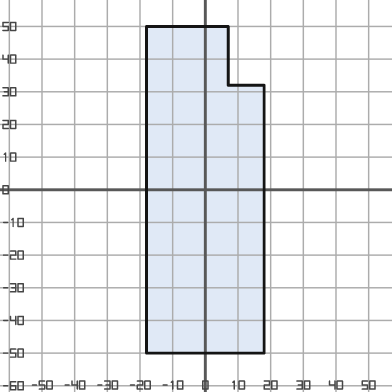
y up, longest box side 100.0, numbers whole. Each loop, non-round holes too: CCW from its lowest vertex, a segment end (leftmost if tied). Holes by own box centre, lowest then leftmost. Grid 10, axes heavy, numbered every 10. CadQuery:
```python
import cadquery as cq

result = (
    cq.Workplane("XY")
    .moveTo(-18.0, -50.0)
    .lineTo(18.0, -50.0)
    .lineTo(18.0, 32.0)
    .lineTo(7.0, 32.0)
    .lineTo(7.0, 50.0)
    .lineTo(-18.0, 50.0)
    .close()
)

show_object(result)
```